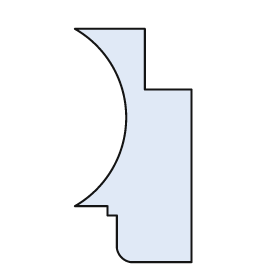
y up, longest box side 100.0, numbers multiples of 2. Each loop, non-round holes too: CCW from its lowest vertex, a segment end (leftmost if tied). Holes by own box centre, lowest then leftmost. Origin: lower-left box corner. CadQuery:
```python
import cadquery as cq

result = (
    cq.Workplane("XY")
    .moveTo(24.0, 0.0)
    .lineTo(50.0, 0.0)
    .lineTo(50.0, 74.0)
    .lineTo(30.0, 74.0)
    .lineTo(30.0, 100.0)
    .lineTo(0.0, 100.0)
    .threePointArc((22.0, 62.0), (0.0, 24.0))
    .lineTo(14.0, 24.0)
    .lineTo(14.0, 20.0)
    .lineTo(18.0, 20.0)
    .lineTo(18.0, 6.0)
    .threePointArc((20.0, 2.0), (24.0, 0.0))
    .close()
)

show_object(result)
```